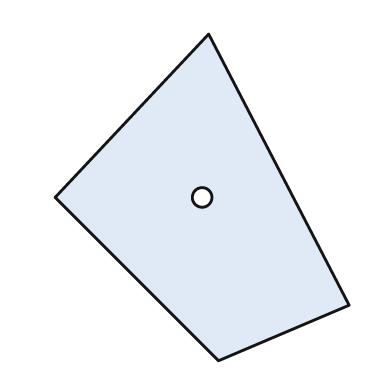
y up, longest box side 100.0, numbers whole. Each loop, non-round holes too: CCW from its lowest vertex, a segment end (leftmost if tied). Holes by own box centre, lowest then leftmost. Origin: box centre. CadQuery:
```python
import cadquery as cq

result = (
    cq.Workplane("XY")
    .moveTo(5.0, -50.0)
    .lineTo(45.0, -33.0)
    .lineTo(2.0, 50.0)
    .lineTo(-45.0, 0.0)
    .close()
    .moveTo(0.0, 0.0)
    .circle(3.0)
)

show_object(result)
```